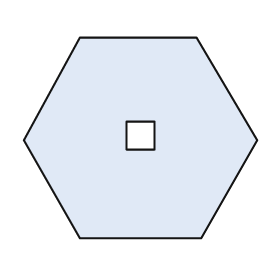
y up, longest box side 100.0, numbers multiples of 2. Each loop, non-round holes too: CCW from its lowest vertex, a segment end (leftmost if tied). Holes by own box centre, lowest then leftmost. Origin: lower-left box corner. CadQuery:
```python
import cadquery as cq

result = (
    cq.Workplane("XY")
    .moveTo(24.0, 0.0)
    .lineTo(76.0, 0.0)
    .lineTo(100.0, 42.0)
    .lineTo(74.0, 86.0)
    .lineTo(24.0, 86.0)
    .lineTo(0.0, 42.0)
    .close()
    .moveTo(44.0, 38.0)
    .lineTo(56.0, 38.0)
    .lineTo(56.0, 50.0)
    .lineTo(44.0, 50.0)
    .close()
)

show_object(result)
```